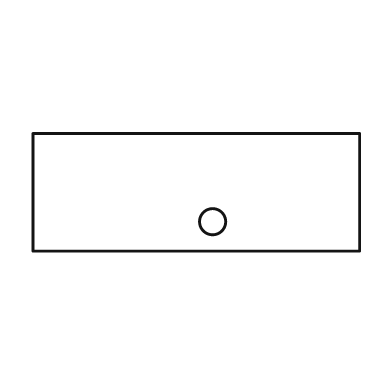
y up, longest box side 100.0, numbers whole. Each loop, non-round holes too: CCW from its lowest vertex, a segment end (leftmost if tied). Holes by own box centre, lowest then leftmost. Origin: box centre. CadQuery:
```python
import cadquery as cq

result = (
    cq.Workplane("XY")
    .moveTo(-50.0, -18.0)
    .lineTo(50.0, -18.0)
    .lineTo(50.0, 18.0)
    .lineTo(-50.0, 18.0)
    .close()
    .moveTo(5.0, -9.0)
    .circle(4.0)
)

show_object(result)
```